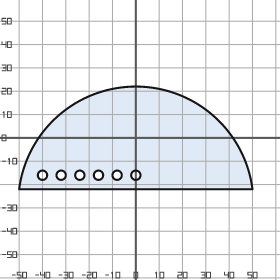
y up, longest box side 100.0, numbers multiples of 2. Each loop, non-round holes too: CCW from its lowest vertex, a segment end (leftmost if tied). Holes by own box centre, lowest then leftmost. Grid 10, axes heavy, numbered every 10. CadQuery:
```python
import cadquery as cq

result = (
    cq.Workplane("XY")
    .moveTo(-50.0, -22.0)
    .lineTo(50.0, -22.0)
    .threePointArc((0.0, 22.0), (-50.0, -22.0))
    .close()
    .moveTo(-40.0, -16.0)
    .circle(2.0)
    .moveTo(-32.0, -16.0)
    .circle(2.0)
    .moveTo(-24.0, -16.0)
    .circle(2.0)
    .moveTo(-16.0, -16.0)
    .circle(2.0)
    .moveTo(-8.0, -16.0)
    .circle(2.0)
    .moveTo(0.0, -16.0)
    .circle(2.0)
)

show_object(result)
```